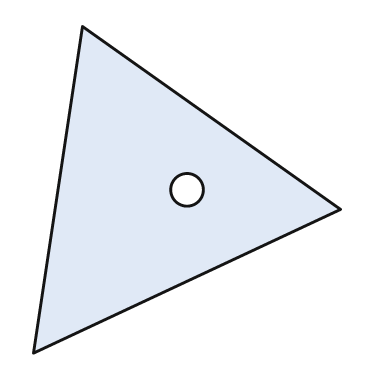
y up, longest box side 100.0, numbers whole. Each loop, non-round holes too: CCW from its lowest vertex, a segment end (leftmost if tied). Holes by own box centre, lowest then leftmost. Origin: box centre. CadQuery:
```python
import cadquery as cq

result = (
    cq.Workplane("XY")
    .moveTo(-47.0, -50.0)
    .lineTo(47.0, -6.0)
    .lineTo(-32.0, 50.0)
    .close()
    .moveTo(0.0, 0.0)
    .circle(5.0)
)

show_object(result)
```